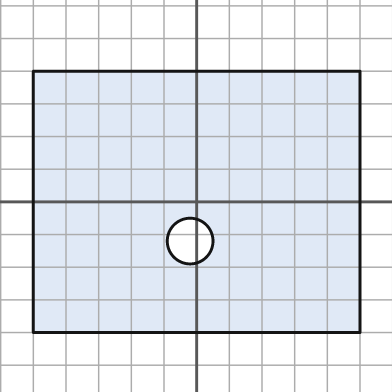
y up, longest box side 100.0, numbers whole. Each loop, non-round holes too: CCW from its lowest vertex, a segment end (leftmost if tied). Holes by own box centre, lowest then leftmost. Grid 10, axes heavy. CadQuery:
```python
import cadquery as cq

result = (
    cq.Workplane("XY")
    .moveTo(-50.0, -40.0)
    .lineTo(50.0, -40.0)
    .lineTo(50.0, 40.0)
    .lineTo(-50.0, 40.0)
    .close()
    .moveTo(-2.0, -12.0)
    .circle(7.0)
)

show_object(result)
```